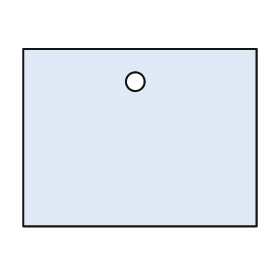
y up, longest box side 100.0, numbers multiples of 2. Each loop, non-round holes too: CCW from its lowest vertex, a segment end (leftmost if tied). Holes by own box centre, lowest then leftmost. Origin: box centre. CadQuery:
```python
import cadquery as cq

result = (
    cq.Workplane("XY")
    .moveTo(-50.0, -38.0)
    .lineTo(50.0, -38.0)
    .lineTo(50.0, 38.0)
    .lineTo(-50.0, 38.0)
    .close()
    .moveTo(-2.0, 24.0)
    .circle(4.0)
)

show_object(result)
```